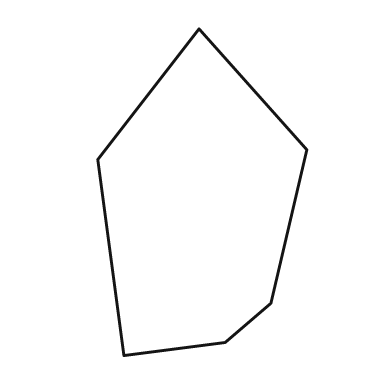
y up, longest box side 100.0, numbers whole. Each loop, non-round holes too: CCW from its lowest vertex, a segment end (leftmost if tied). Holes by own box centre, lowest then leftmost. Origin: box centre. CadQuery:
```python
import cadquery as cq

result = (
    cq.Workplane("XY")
    .moveTo(-24.0, -50.0)
    .lineTo(7.0, -46.0)
    .lineTo(21.0, -34.0)
    .lineTo(32.0, 13.0)
    .lineTo(-1.0, 50.0)
    .lineTo(-32.0, 10.0)
    .close()
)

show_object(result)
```